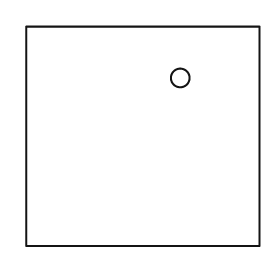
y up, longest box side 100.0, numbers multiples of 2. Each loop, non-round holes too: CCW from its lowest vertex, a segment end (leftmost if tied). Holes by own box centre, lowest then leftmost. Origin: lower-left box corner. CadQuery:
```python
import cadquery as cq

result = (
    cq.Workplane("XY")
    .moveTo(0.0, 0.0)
    .lineTo(100.0, 0.0)
    .lineTo(100.0, 94.0)
    .lineTo(0.0, 94.0)
    .close()
    .moveTo(66.0, 72.0)
    .circle(4.0)
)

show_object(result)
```